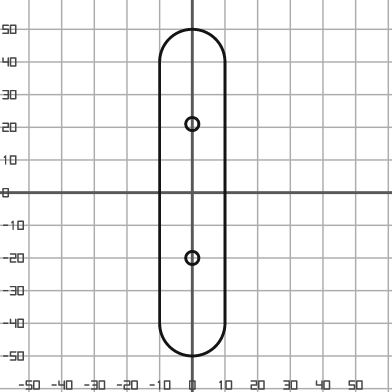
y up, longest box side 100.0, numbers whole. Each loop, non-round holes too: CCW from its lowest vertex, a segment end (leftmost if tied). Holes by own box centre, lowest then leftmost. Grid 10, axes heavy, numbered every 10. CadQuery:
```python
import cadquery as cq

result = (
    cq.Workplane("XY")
    .moveTo(-10.0, -40.0)
    .threePointArc((0.0, -50.0), (10.0, -40.0))
    .lineTo(10.0, 40.0)
    .threePointArc((0.0, 50.0), (-10.0, 40.0))
    .close()
    .moveTo(0.0, -20.0)
    .circle(2.0)
    .moveTo(0.0, 21.0)
    .circle(2.0)
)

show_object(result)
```